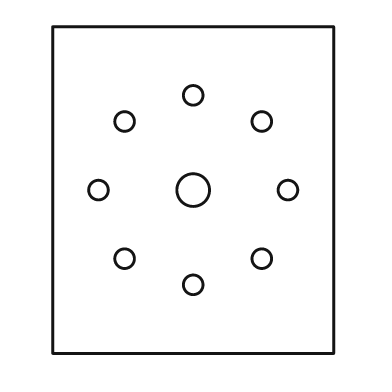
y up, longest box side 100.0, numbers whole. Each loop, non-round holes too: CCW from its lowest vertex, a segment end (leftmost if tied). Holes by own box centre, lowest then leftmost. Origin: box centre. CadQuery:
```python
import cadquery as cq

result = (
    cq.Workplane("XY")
    .moveTo(-43.0, -50.0)
    .lineTo(43.0, -50.0)
    .lineTo(43.0, 50.0)
    .lineTo(-43.0, 50.0)
    .close()
    .moveTo(0.0, -29.0)
    .circle(3.0)
    .moveTo(-21.0, -21.0)
    .circle(3.0)
    .moveTo(21.0, -21.0)
    .circle(3.0)
    .moveTo(-29.0, 0.0)
    .circle(3.0)
    .moveTo(0.0, 0.0)
    .circle(5.0)
    .moveTo(29.0, 0.0)
    .circle(3.0)
    .moveTo(-21.0, 21.0)
    .circle(3.0)
    .moveTo(21.0, 21.0)
    .circle(3.0)
    .moveTo(0.0, 29.0)
    .circle(3.0)
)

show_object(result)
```